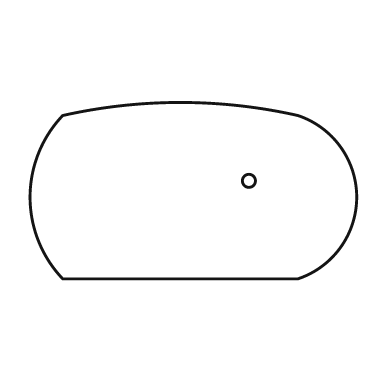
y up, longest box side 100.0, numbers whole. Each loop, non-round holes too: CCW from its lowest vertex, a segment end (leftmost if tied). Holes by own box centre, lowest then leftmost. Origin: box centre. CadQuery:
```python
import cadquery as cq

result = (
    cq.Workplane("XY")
    .moveTo(-40.0, -27.0)
    .lineTo(32.0, -27.0)
    .threePointArc((50.0, -2.0), (32.0, 23.0))
    .threePointArc((-4.0, 27.0), (-40.0, 23.0))
    .threePointArc((-50.0, -2.0), (-40.0, -27.0))
    .close()
    .moveTo(17.0, 3.0)
    .circle(2.0)
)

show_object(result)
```